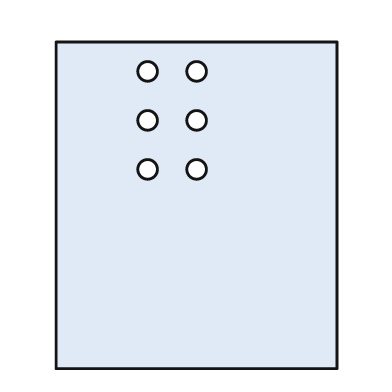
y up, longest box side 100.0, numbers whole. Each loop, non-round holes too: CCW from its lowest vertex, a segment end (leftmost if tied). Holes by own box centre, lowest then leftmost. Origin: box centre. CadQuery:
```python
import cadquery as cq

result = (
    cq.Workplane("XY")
    .moveTo(-43.0, -50.0)
    .lineTo(43.0, -50.0)
    .lineTo(43.0, 50.0)
    .lineTo(-43.0, 50.0)
    .close()
    .moveTo(-15.0, 11.0)
    .circle(3.0)
    .moveTo(0.0, 11.0)
    .circle(3.0)
    .moveTo(-15.0, 26.0)
    .circle(3.0)
    .moveTo(0.0, 26.0)
    .circle(3.0)
    .moveTo(-15.0, 41.0)
    .circle(3.0)
    .moveTo(0.0, 41.0)
    .circle(3.0)
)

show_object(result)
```